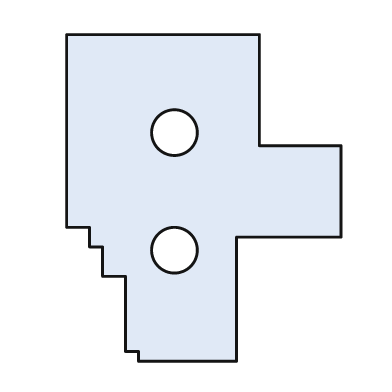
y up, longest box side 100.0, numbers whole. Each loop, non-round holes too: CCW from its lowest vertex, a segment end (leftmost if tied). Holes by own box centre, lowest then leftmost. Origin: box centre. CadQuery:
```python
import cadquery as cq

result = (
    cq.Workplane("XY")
    .moveTo(-20.0, -50.0)
    .lineTo(10.0, -50.0)
    .lineTo(10.0, -12.0)
    .lineTo(42.0, -12.0)
    .lineTo(42.0, 16.0)
    .lineTo(17.0, 16.0)
    .lineTo(17.0, 50.0)
    .lineTo(-42.0, 50.0)
    .lineTo(-42.0, -9.0)
    .lineTo(-35.0, -9.0)
    .lineTo(-35.0, -15.0)
    .lineTo(-31.0, -15.0)
    .lineTo(-31.0, -24.0)
    .lineTo(-24.0, -24.0)
    .lineTo(-24.0, -47.0)
    .lineTo(-20.0, -47.0)
    .close()
    .moveTo(-9.0, -16.0)
    .circle(7.0)
    .moveTo(-9.0, 20.0)
    .circle(7.0)
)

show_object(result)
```